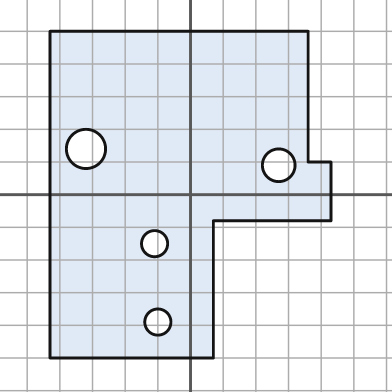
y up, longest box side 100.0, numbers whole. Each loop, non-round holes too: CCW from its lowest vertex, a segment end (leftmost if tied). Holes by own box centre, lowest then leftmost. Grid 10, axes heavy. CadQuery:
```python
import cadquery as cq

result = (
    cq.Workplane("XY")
    .moveTo(-43.0, -50.0)
    .lineTo(7.0, -50.0)
    .lineTo(7.0, -8.0)
    .lineTo(43.0, -8.0)
    .lineTo(43.0, 10.0)
    .lineTo(36.0, 10.0)
    .lineTo(36.0, 50.0)
    .lineTo(-43.0, 50.0)
    .close()
    .moveTo(-10.0, -39.0)
    .circle(4.0)
    .moveTo(-11.0, -15.0)
    .circle(4.0)
    .moveTo(27.0, 9.0)
    .circle(5.0)
    .moveTo(-32.0, 14.0)
    .circle(6.0)
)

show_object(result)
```